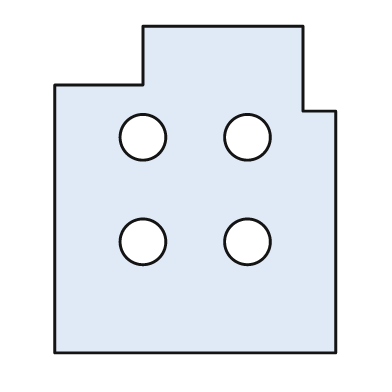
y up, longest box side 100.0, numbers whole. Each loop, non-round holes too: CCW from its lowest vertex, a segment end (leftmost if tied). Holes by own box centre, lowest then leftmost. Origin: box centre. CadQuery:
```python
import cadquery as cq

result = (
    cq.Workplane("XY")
    .moveTo(-43.0, -50.0)
    .lineTo(43.0, -50.0)
    .lineTo(43.0, 24.0)
    .lineTo(33.0, 24.0)
    .lineTo(33.0, 50.0)
    .lineTo(-16.0, 50.0)
    .lineTo(-16.0, 32.0)
    .lineTo(-43.0, 32.0)
    .close()
    .moveTo(-16.0, -16.0)
    .circle(7.0)
    .moveTo(16.0, -16.0)
    .circle(7.0)
    .moveTo(-16.0, 16.0)
    .circle(7.0)
    .moveTo(16.0, 16.0)
    .circle(7.0)
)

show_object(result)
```